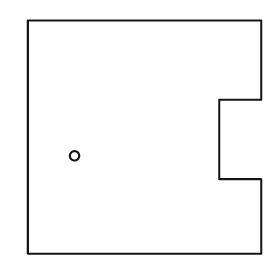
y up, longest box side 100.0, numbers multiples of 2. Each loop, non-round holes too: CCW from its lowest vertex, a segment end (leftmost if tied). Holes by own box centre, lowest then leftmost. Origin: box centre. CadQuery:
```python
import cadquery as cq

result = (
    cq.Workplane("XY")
    .moveTo(-50.0, -50.0)
    .lineTo(50.0, -50.0)
    .lineTo(50.0, -18.0)
    .lineTo(32.0, -18.0)
    .lineTo(32.0, 16.0)
    .lineTo(50.0, 16.0)
    .lineTo(50.0, 50.0)
    .lineTo(-50.0, 50.0)
    .close()
    .moveTo(-30.0, -8.0)
    .circle(2.0)
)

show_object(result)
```